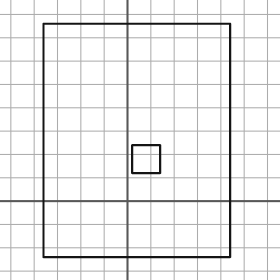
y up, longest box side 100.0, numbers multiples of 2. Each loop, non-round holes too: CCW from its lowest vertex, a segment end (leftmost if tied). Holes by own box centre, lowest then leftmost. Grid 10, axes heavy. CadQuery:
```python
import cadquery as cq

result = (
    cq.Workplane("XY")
    .moveTo(-36.0, -24.0)
    .lineTo(44.0, -24.0)
    .lineTo(44.0, 76.0)
    .lineTo(-36.0, 76.0)
    .close()
    .moveTo(2.0, 12.0)
    .lineTo(14.0, 12.0)
    .lineTo(14.0, 24.0)
    .lineTo(2.0, 24.0)
    .close()
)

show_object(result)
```